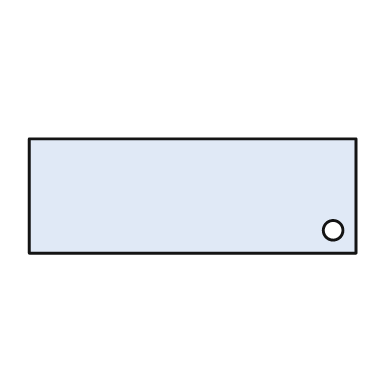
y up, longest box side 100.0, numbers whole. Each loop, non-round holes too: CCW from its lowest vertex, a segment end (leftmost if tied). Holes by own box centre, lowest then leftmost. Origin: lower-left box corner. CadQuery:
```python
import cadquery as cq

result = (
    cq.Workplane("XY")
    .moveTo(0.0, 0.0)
    .lineTo(100.0, 0.0)
    .lineTo(100.0, 35.0)
    .lineTo(0.0, 35.0)
    .close()
    .moveTo(93.0, 7.0)
    .circle(3.0)
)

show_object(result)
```